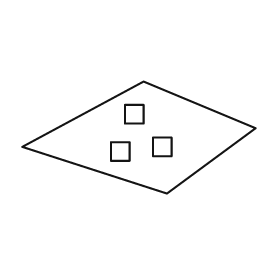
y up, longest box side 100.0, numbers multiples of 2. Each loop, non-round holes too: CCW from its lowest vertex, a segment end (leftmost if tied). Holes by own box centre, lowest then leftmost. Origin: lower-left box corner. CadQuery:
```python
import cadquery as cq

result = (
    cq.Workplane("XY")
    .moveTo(62.0, 0.0)
    .lineTo(100.0, 28.0)
    .lineTo(52.0, 48.0)
    .lineTo(0.0, 20.0)
    .close()
    .moveTo(38.0, 14.0)
    .lineTo(46.0, 14.0)
    .lineTo(46.0, 22.0)
    .lineTo(38.0, 22.0)
    .close()
    .moveTo(56.0, 16.0)
    .lineTo(64.0, 16.0)
    .lineTo(64.0, 24.0)
    .lineTo(56.0, 24.0)
    .close()
    .moveTo(44.0, 30.0)
    .lineTo(52.0, 30.0)
    .lineTo(52.0, 38.0)
    .lineTo(44.0, 38.0)
    .close()
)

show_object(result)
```